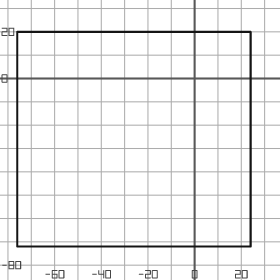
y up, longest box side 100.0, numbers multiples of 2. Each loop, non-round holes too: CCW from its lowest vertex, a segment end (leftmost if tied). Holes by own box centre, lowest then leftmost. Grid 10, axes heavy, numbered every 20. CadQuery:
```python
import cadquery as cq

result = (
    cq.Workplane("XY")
    .moveTo(-76.0, -72.0)
    .lineTo(24.0, -72.0)
    .lineTo(24.0, 20.0)
    .lineTo(-76.0, 20.0)
    .close()
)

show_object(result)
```